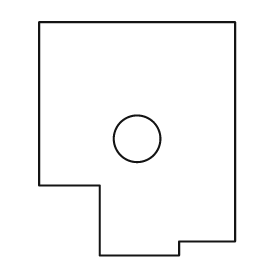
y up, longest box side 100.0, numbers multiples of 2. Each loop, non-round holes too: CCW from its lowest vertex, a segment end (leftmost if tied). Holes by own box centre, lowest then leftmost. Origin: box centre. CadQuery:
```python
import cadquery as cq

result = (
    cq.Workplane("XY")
    .moveTo(-16.0, -50.0)
    .lineTo(18.0, -50.0)
    .lineTo(18.0, -44.0)
    .lineTo(42.0, -44.0)
    .lineTo(42.0, 50.0)
    .lineTo(-42.0, 50.0)
    .lineTo(-42.0, -20.0)
    .lineTo(-16.0, -20.0)
    .close()
    .moveTo(0.0, 0.0)
    .circle(10.0)
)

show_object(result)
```